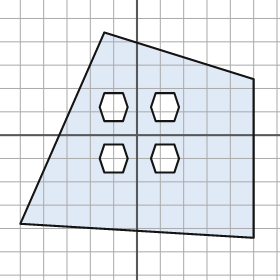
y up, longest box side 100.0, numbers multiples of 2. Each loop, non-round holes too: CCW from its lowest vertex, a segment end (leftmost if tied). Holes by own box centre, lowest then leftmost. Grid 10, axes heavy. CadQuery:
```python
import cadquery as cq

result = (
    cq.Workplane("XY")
    .moveTo(50.0, -44.0)
    .lineTo(50.0, 24.0)
    .lineTo(-14.0, 44.0)
    .lineTo(-50.0, -38.0)
    .close()
    .moveTo(-14.0, -16.0)
    .lineTo(-6.0, -16.0)
    .lineTo(-4.0, -10.0)
    .lineTo(-6.0, -4.0)
    .lineTo(-14.0, -4.0)
    .lineTo(-16.0, -10.0)
    .close()
    .moveTo(8.0, -16.0)
    .lineTo(16.0, -16.0)
    .lineTo(18.0, -10.0)
    .lineTo(16.0, -4.0)
    .lineTo(8.0, -4.0)
    .lineTo(6.0, -10.0)
    .close()
    .moveTo(-14.0, 6.0)
    .lineTo(-6.0, 6.0)
    .lineTo(-4.0, 12.0)
    .lineTo(-6.0, 18.0)
    .lineTo(-14.0, 18.0)
    .lineTo(-16.0, 12.0)
    .close()
    .moveTo(8.0, 6.0)
    .lineTo(16.0, 6.0)
    .lineTo(18.0, 12.0)
    .lineTo(16.0, 18.0)
    .lineTo(8.0, 18.0)
    .lineTo(6.0, 12.0)
    .close()
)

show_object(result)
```